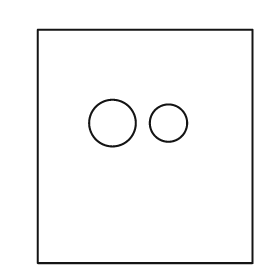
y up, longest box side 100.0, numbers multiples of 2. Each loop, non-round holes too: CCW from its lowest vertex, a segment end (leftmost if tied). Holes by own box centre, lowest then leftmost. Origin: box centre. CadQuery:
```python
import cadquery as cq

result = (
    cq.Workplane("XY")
    .moveTo(-46.0, -50.0)
    .lineTo(46.0, -50.0)
    .lineTo(46.0, 50.0)
    .lineTo(-46.0, 50.0)
    .close()
    .moveTo(-14.0, 10.0)
    .circle(10.0)
    .moveTo(10.0, 10.0)
    .circle(8.0)
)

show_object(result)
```